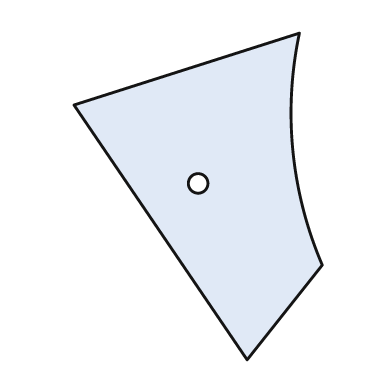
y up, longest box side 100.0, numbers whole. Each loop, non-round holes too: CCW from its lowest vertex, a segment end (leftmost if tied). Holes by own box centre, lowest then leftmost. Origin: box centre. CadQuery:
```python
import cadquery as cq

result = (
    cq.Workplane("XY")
    .moveTo(15.0, -50.0)
    .lineTo(38.0, -21.0)
    .threePointArc((29.0, 14.0), (31.0, 50.0))
    .lineTo(-38.0, 28.0)
    .close()
    .moveTo(0.0, 4.0)
    .circle(3.0)
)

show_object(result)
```